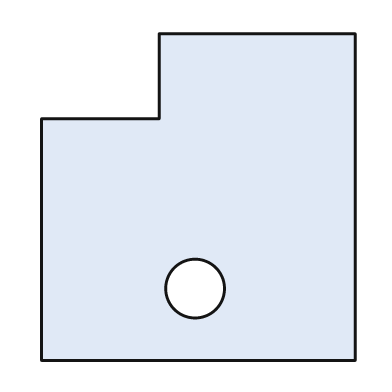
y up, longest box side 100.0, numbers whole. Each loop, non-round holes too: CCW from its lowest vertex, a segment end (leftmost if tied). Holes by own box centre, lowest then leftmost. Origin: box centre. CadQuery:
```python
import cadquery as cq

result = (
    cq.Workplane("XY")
    .moveTo(-48.0, -50.0)
    .lineTo(48.0, -50.0)
    .lineTo(48.0, 50.0)
    .lineTo(-12.0, 50.0)
    .lineTo(-12.0, 24.0)
    .lineTo(-48.0, 24.0)
    .close()
    .moveTo(-1.0, -28.0)
    .circle(9.0)
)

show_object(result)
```